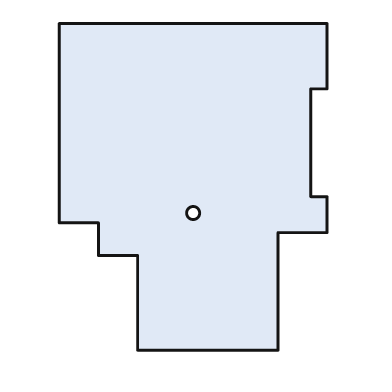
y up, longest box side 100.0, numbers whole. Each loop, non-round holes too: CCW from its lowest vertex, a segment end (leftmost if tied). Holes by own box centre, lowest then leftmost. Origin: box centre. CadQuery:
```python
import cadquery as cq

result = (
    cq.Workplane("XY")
    .moveTo(-17.0, -50.0)
    .lineTo(26.0, -50.0)
    .lineTo(26.0, -14.0)
    .lineTo(41.0, -14.0)
    .lineTo(41.0, -3.0)
    .lineTo(36.0, -3.0)
    .lineTo(36.0, 30.0)
    .lineTo(41.0, 30.0)
    .lineTo(41.0, 50.0)
    .lineTo(-41.0, 50.0)
    .lineTo(-41.0, -11.0)
    .lineTo(-29.0, -11.0)
    .lineTo(-29.0, -21.0)
    .lineTo(-17.0, -21.0)
    .close()
    .moveTo(0.0, -8.0)
    .circle(2.0)
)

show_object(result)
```